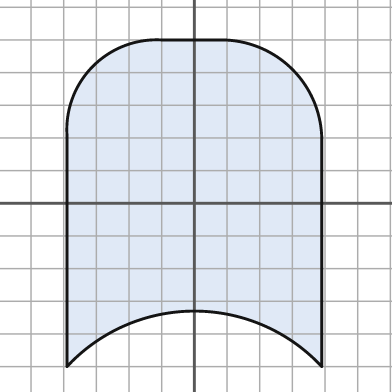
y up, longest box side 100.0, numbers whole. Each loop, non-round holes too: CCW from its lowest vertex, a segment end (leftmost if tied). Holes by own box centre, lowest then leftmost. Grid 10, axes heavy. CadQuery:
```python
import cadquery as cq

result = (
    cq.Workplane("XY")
    .moveTo(-39.0, -50.0)
    .threePointArc((0.0, -33.0), (39.0, -50.0))
    .lineTo(39.0, 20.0)
    .threePointArc((30.0, 41.0), (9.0, 50.0))
    .lineTo(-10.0, 50.0)
    .threePointArc((-31.0, 42.0), (-39.0, 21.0))
    .close()
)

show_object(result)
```